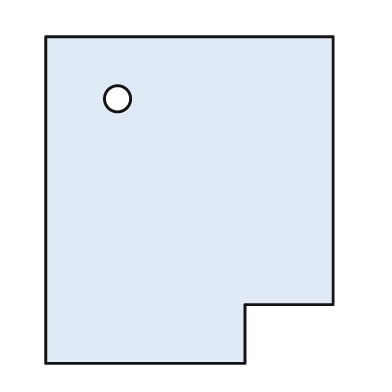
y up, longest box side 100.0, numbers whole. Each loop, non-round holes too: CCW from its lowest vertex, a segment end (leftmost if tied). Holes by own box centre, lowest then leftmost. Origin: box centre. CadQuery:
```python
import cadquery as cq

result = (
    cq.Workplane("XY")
    .moveTo(-44.0, -50.0)
    .lineTo(17.0, -50.0)
    .lineTo(17.0, -32.0)
    .lineTo(44.0, -32.0)
    .lineTo(44.0, 50.0)
    .lineTo(-44.0, 50.0)
    .close()
    .moveTo(-22.0, 31.0)
    .circle(4.0)
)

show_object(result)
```